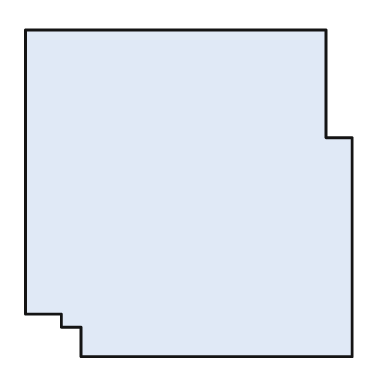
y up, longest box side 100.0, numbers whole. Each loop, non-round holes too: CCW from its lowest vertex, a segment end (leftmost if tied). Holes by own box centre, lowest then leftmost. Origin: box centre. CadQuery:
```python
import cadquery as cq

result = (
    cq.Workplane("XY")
    .moveTo(-33.0, -50.0)
    .lineTo(50.0, -50.0)
    .lineTo(50.0, 17.0)
    .lineTo(42.0, 17.0)
    .lineTo(42.0, 50.0)
    .lineTo(-50.0, 50.0)
    .lineTo(-50.0, -37.0)
    .lineTo(-39.0, -37.0)
    .lineTo(-39.0, -41.0)
    .lineTo(-33.0, -41.0)
    .close()
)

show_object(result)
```